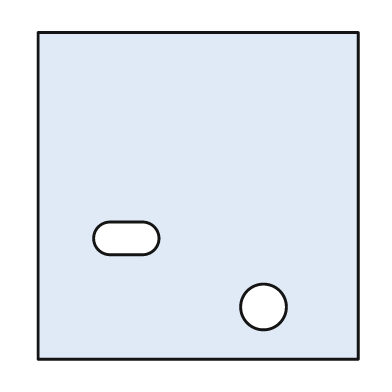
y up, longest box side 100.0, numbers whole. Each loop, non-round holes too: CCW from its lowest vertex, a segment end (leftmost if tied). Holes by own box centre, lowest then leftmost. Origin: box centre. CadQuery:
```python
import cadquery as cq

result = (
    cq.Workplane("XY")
    .moveTo(-49.0, -50.0)
    .lineTo(49.0, -50.0)
    .lineTo(49.0, 50.0)
    .lineTo(-49.0, 50.0)
    .close()
    .moveTo(20.0, -34.0)
    .circle(7.0)
    .moveTo(-27.0, -18.0)
    .lineTo(-17.0, -18.0)
    .threePointArc((-12.0, -13.0), (-17.0, -8.0))
    .lineTo(-27.0, -8.0)
    .threePointArc((-32.0, -13.0), (-27.0, -18.0))
    .close()
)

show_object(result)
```